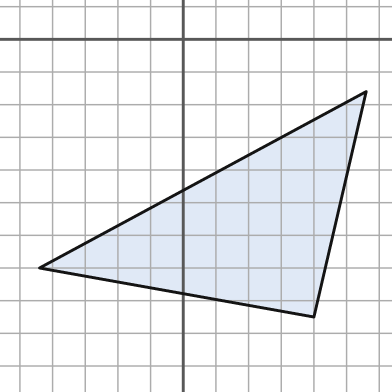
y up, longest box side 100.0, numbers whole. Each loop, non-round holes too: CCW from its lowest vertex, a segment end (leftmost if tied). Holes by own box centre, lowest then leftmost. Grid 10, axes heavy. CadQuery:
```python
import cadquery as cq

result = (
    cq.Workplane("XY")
    .moveTo(40.0, -85.0)
    .lineTo(56.0, -16.0)
    .lineTo(-44.0, -70.0)
    .close()
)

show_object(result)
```